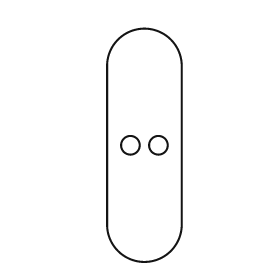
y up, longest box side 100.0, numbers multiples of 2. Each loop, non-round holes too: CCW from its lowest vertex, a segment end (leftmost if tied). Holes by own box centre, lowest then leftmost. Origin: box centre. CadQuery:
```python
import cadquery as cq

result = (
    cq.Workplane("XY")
    .moveTo(-16.0, -34.0)
    .threePointArc((0.0, -50.0), (16.0, -34.0))
    .lineTo(16.0, 34.0)
    .threePointArc((0.0, 50.0), (-16.0, 34.0))
    .close()
    .moveTo(-6.0, 0.0)
    .circle(4.0)
    .moveTo(6.0, 0.0)
    .circle(4.0)
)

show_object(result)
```